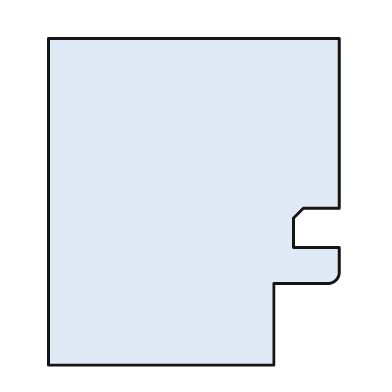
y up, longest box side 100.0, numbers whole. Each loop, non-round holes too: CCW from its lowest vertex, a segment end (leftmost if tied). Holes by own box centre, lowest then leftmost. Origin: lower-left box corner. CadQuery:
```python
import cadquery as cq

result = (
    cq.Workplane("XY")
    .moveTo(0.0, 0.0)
    .lineTo(69.0, 0.0)
    .lineTo(69.0, 25.0)
    .lineTo(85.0, 25.0)
    .threePointArc((88.0, 26.0), (89.0, 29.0))
    .lineTo(89.0, 36.0)
    .lineTo(75.0, 36.0)
    .lineTo(75.0, 45.0)
    .lineTo(78.0, 48.0)
    .lineTo(89.0, 48.0)
    .lineTo(89.0, 100.0)
    .lineTo(0.0, 100.0)
    .close()
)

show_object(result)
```